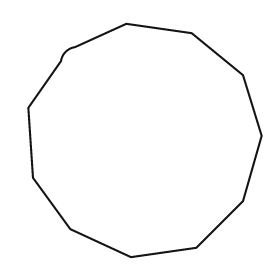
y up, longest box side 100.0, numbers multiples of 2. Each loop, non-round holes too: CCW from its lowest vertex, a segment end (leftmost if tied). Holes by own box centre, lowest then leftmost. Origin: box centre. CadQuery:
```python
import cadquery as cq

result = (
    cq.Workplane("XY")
    .moveTo(-6.0, -50.0)
    .lineTo(22.0, -46.0)
    .lineTo(42.0, -26.0)
    .lineTo(50.0, 2.0)
    .lineTo(42.0, 28.0)
    .lineTo(20.0, 46.0)
    .lineTo(-8.0, 50.0)
    .lineTo(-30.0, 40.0)
    .threePointArc((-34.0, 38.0), (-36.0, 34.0))
    .lineTo(-50.0, 14.0)
    .lineTo(-48.0, -16.0)
    .lineTo(-32.0, -38.0)
    .close()
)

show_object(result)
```